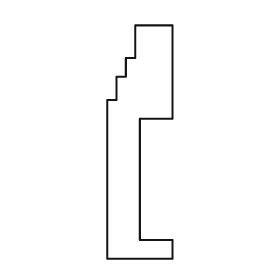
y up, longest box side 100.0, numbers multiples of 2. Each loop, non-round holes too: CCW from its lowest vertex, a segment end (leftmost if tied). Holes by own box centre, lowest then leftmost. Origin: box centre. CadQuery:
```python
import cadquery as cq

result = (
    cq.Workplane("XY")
    .moveTo(-14.0, -50.0)
    .lineTo(14.0, -50.0)
    .lineTo(14.0, -42.0)
    .lineTo(0.0, -42.0)
    .lineTo(0.0, 10.0)
    .lineTo(14.0, 10.0)
    .lineTo(14.0, 50.0)
    .lineTo(-2.0, 50.0)
    .lineTo(-2.0, 36.0)
    .lineTo(-6.0, 36.0)
    .lineTo(-6.0, 28.0)
    .lineTo(-10.0, 28.0)
    .lineTo(-10.0, 18.0)
    .lineTo(-14.0, 18.0)
    .close()
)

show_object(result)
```